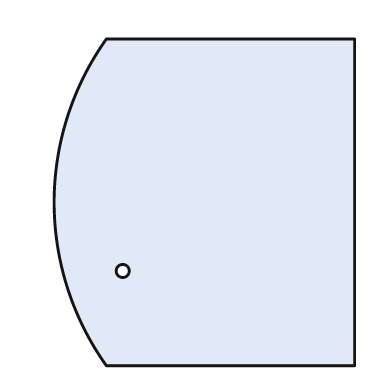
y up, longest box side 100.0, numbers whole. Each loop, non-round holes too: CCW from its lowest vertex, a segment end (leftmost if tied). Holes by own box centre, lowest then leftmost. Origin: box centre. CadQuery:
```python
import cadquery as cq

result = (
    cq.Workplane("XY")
    .moveTo(-30.0, -50.0)
    .lineTo(46.0, -50.0)
    .lineTo(46.0, 50.0)
    .lineTo(-30.0, 50.0)
    .threePointArc((-46.0, 0.0), (-30.0, -50.0))
    .close()
    .moveTo(-25.0, -21.0)
    .circle(2.0)
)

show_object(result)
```